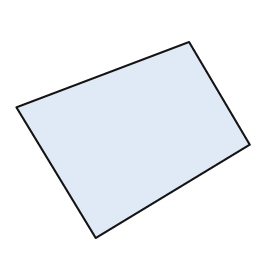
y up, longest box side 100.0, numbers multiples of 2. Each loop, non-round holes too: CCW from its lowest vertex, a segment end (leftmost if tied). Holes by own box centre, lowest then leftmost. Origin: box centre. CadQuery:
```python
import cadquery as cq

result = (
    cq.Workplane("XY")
    .moveTo(-16.0, -42.0)
    .lineTo(50.0, -2.0)
    .lineTo(24.0, 42.0)
    .lineTo(-50.0, 14.0)
    .close()
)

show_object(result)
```